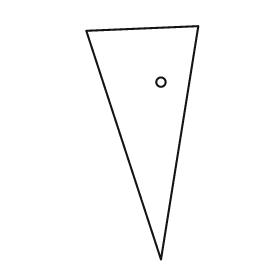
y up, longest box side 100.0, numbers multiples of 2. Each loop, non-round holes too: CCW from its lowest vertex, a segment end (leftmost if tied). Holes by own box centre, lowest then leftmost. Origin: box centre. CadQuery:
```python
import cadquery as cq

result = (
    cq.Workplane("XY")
    .moveTo(8.0, -50.0)
    .lineTo(24.0, 50.0)
    .lineTo(-24.0, 48.0)
    .close()
    .moveTo(8.0, 26.0)
    .circle(2.0)
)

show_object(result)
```